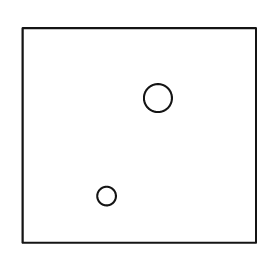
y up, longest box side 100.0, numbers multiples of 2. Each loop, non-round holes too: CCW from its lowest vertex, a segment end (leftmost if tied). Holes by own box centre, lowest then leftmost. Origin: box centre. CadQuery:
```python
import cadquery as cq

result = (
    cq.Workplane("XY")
    .moveTo(-50.0, -46.0)
    .lineTo(50.0, -46.0)
    .lineTo(50.0, 46.0)
    .lineTo(-50.0, 46.0)
    .close()
    .moveTo(-14.0, -26.0)
    .circle(4.0)
    .moveTo(8.0, 16.0)
    .circle(6.0)
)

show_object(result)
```